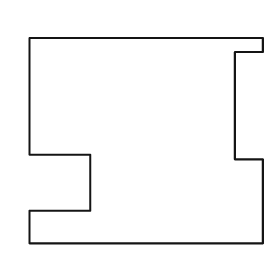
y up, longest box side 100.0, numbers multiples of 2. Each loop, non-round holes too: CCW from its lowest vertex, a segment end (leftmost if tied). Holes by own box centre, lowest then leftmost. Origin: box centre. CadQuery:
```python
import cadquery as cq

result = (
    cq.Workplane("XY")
    .moveTo(-50.0, -44.0)
    .lineTo(50.0, -44.0)
    .lineTo(50.0, -8.0)
    .lineTo(38.0, -8.0)
    .lineTo(38.0, 38.0)
    .lineTo(50.0, 38.0)
    .lineTo(50.0, 44.0)
    .lineTo(-50.0, 44.0)
    .lineTo(-50.0, -6.0)
    .lineTo(-24.0, -6.0)
    .lineTo(-24.0, -30.0)
    .lineTo(-50.0, -30.0)
    .close()
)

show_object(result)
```